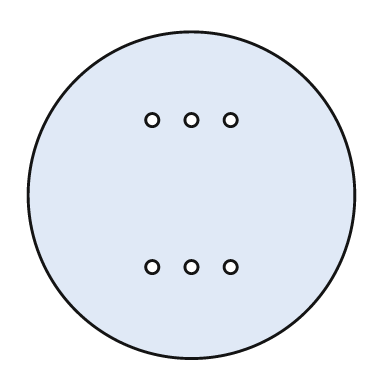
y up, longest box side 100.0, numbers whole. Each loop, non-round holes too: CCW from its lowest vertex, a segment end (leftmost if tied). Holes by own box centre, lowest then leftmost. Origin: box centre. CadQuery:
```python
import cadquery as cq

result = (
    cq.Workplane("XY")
    .moveTo(0.0, 0.0)
    .circle(50.0)
    .moveTo(-12.0, -22.0)
    .circle(2.0)
    .moveTo(0.0, -22.0)
    .circle(2.0)
    .moveTo(12.0, -22.0)
    .circle(2.0)
    .moveTo(-12.0, 23.0)
    .circle(2.0)
    .moveTo(0.0, 23.0)
    .circle(2.0)
    .moveTo(12.0, 23.0)
    .circle(2.0)
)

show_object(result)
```